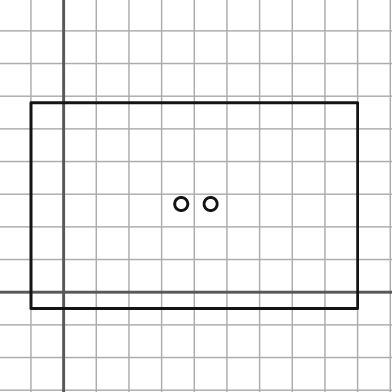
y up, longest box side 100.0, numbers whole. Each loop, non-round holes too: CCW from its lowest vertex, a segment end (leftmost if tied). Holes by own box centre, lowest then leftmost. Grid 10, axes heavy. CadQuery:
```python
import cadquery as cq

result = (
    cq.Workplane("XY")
    .moveTo(-10.0, -5.0)
    .lineTo(90.0, -5.0)
    .lineTo(90.0, 58.0)
    .lineTo(-10.0, 58.0)
    .close()
    .moveTo(36.0, 27.0)
    .circle(2.0)
    .moveTo(45.0, 27.0)
    .circle(2.0)
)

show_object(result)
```